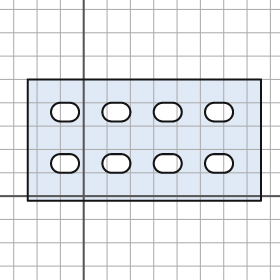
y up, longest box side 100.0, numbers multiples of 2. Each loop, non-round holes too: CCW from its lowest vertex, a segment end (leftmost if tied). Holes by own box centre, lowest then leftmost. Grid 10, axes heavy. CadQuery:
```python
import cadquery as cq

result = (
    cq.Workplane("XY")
    .moveTo(-24.0, -2.0)
    .lineTo(76.0, -2.0)
    .lineTo(76.0, 50.0)
    .lineTo(-24.0, 50.0)
    .close()
    .moveTo(-10.0, 10.0)
    .lineTo(-6.0, 10.0)
    .threePointArc((-2.0, 14.0), (-6.0, 18.0))
    .lineTo(-10.0, 18.0)
    .threePointArc((-14.0, 14.0), (-10.0, 10.0))
    .close()
    .moveTo(12.0, 10.0)
    .lineTo(16.0, 10.0)
    .threePointArc((20.0, 14.0), (16.0, 18.0))
    .lineTo(12.0, 18.0)
    .threePointArc((8.0, 14.0), (12.0, 10.0))
    .close()
    .moveTo(34.0, 10.0)
    .lineTo(38.0, 10.0)
    .threePointArc((42.0, 14.0), (38.0, 18.0))
    .lineTo(34.0, 18.0)
    .threePointArc((30.0, 14.0), (34.0, 10.0))
    .close()
    .moveTo(56.0, 10.0)
    .lineTo(60.0, 10.0)
    .threePointArc((64.0, 14.0), (60.0, 18.0))
    .lineTo(56.0, 18.0)
    .threePointArc((52.0, 14.0), (56.0, 10.0))
    .close()
    .moveTo(-10.0, 32.0)
    .lineTo(-6.0, 32.0)
    .threePointArc((-2.0, 36.0), (-6.0, 40.0))
    .lineTo(-10.0, 40.0)
    .threePointArc((-14.0, 36.0), (-10.0, 32.0))
    .close()
    .moveTo(12.0, 32.0)
    .lineTo(16.0, 32.0)
    .threePointArc((20.0, 36.0), (16.0, 40.0))
    .lineTo(12.0, 40.0)
    .threePointArc((8.0, 36.0), (12.0, 32.0))
    .close()
    .moveTo(34.0, 32.0)
    .lineTo(38.0, 32.0)
    .threePointArc((42.0, 36.0), (38.0, 40.0))
    .lineTo(34.0, 40.0)
    .threePointArc((30.0, 36.0), (34.0, 32.0))
    .close()
    .moveTo(56.0, 32.0)
    .lineTo(60.0, 32.0)
    .threePointArc((64.0, 36.0), (60.0, 40.0))
    .lineTo(56.0, 40.0)
    .threePointArc((52.0, 36.0), (56.0, 32.0))
    .close()
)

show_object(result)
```